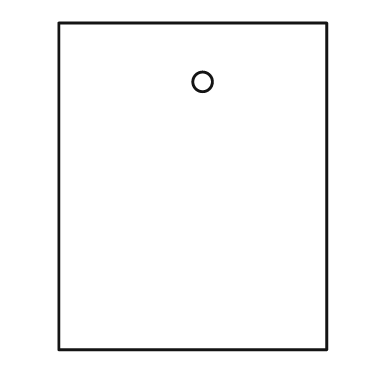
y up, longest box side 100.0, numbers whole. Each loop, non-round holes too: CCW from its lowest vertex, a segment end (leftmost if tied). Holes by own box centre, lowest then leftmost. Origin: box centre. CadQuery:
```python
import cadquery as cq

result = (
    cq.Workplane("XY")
    .moveTo(-41.0, -50.0)
    .lineTo(41.0, -50.0)
    .lineTo(41.0, 50.0)
    .lineTo(-41.0, 50.0)
    .close()
    .moveTo(3.0, 32.0)
    .circle(3.0)
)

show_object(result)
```